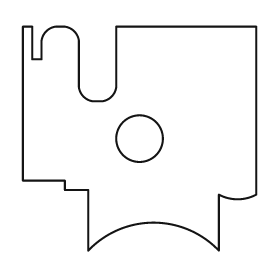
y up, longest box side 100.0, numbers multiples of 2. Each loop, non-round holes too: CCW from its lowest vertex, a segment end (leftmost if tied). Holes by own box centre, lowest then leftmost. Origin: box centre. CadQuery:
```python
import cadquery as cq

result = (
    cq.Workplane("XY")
    .moveTo(-22.0, -48.0)
    .threePointArc((6.0, -36.0), (34.0, -48.0))
    .lineTo(34.0, -24.0)
    .threePointArc((42.0, -26.0), (50.0, -24.0))
    .lineTo(50.0, 48.0)
    .lineTo(-10.0, 48.0)
    .lineTo(-10.0, 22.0)
    .threePointArc((-12.0, 18.0), (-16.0, 16.0))
    .lineTo(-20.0, 16.0)
    .threePointArc((-24.0, 18.0), (-26.0, 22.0))
    .lineTo(-26.0, 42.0)
    .threePointArc((-28.0, 46.0), (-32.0, 48.0))
    .lineTo(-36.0, 48.0)
    .threePointArc((-40.0, 46.0), (-42.0, 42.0))
    .lineTo(-42.0, 34.0)
    .lineTo(-46.0, 34.0)
    .lineTo(-46.0, 48.0)
    .lineTo(-50.0, 48.0)
    .lineTo(-50.0, -18.0)
    .lineTo(-32.0, -18.0)
    .lineTo(-32.0, -22.0)
    .lineTo(-22.0, -22.0)
    .close()
    .moveTo(0.0, 0.0)
    .circle(10.0)
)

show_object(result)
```